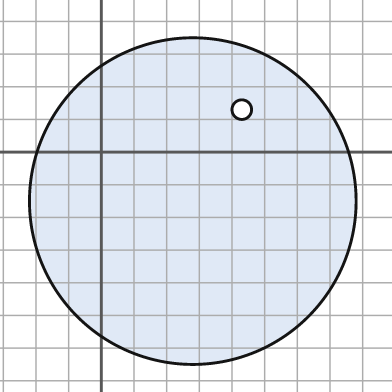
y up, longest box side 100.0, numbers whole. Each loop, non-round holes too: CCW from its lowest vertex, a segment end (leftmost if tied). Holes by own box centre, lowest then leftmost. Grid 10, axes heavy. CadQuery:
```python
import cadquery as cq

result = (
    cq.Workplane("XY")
    .moveTo(28.0, -15.0)
    .circle(50.0)
    .moveTo(43.0, 13.0)
    .circle(3.0)
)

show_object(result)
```